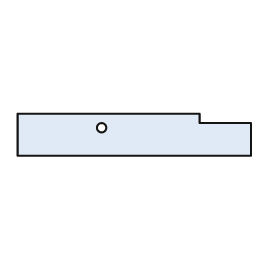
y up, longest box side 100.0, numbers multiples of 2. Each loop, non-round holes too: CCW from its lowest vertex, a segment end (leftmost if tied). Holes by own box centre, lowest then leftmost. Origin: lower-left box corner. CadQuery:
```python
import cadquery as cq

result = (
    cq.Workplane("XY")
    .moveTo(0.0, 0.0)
    .lineTo(100.0, 0.0)
    .lineTo(100.0, 14.0)
    .lineTo(78.0, 14.0)
    .lineTo(78.0, 18.0)
    .lineTo(0.0, 18.0)
    .close()
    .moveTo(36.0, 12.0)
    .circle(2.0)
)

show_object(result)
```